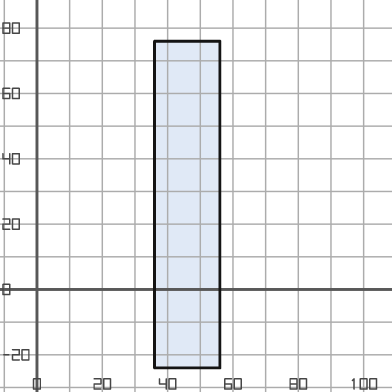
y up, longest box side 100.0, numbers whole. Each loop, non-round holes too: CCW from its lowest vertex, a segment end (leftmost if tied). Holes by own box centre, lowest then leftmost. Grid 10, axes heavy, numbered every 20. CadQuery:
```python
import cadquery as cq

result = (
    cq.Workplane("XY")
    .moveTo(36.0, -24.0)
    .lineTo(56.0, -24.0)
    .lineTo(56.0, 76.0)
    .lineTo(36.0, 76.0)
    .close()
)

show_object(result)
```